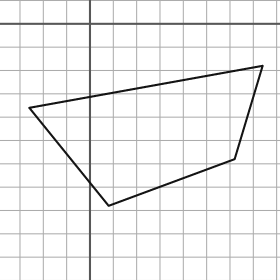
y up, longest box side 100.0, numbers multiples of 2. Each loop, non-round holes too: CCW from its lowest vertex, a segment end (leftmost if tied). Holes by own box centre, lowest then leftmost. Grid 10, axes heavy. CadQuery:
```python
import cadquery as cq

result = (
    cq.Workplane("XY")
    .moveTo(8.0, -78.0)
    .lineTo(62.0, -58.0)
    .lineTo(74.0, -18.0)
    .lineTo(-26.0, -36.0)
    .close()
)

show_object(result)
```